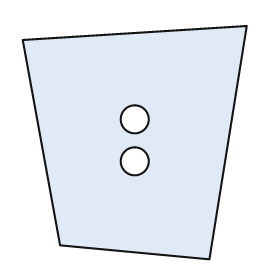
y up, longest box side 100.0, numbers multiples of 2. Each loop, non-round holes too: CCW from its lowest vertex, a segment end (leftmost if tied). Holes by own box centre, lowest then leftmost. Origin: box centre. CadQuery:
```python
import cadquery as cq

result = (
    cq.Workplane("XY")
    .moveTo(32.0, -50.0)
    .lineTo(48.0, 50.0)
    .lineTo(-48.0, 44.0)
    .lineTo(-32.0, -44.0)
    .close()
    .moveTo(0.0, -8.0)
    .circle(6.0)
    .moveTo(0.0, 10.0)
    .circle(6.0)
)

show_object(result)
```